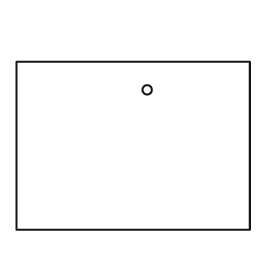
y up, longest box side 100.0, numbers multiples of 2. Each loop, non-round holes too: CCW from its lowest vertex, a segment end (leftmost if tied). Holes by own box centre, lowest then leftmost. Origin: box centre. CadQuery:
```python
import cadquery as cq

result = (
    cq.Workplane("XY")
    .moveTo(-50.0, -36.0)
    .lineTo(50.0, -36.0)
    .lineTo(50.0, 36.0)
    .lineTo(-50.0, 36.0)
    .close()
    .moveTo(6.0, 24.0)
    .circle(2.0)
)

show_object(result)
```